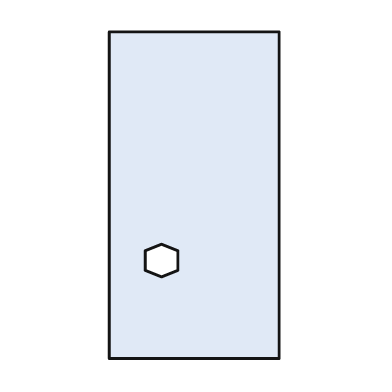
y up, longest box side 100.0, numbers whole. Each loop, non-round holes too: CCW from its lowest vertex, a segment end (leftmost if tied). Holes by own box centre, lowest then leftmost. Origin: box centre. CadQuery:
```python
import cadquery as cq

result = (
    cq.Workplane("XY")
    .moveTo(-26.0, -50.0)
    .lineTo(26.0, -50.0)
    .lineTo(26.0, 50.0)
    .lineTo(-26.0, 50.0)
    .close()
    .moveTo(-10.0, -25.0)
    .lineTo(-5.0, -23.0)
    .lineTo(-5.0, -17.0)
    .lineTo(-10.0, -15.0)
    .lineTo(-15.0, -17.0)
    .lineTo(-15.0, -23.0)
    .close()
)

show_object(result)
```